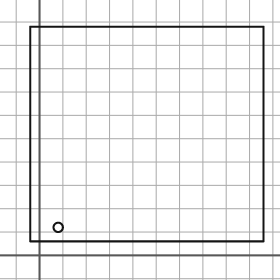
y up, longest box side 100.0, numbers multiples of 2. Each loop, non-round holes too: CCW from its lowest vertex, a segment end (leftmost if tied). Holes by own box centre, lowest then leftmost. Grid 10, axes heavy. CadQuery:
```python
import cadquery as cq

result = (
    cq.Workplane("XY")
    .moveTo(-4.0, 6.0)
    .lineTo(96.0, 6.0)
    .lineTo(96.0, 98.0)
    .lineTo(-4.0, 98.0)
    .close()
    .moveTo(8.0, 12.0)
    .circle(2.0)
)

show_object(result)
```